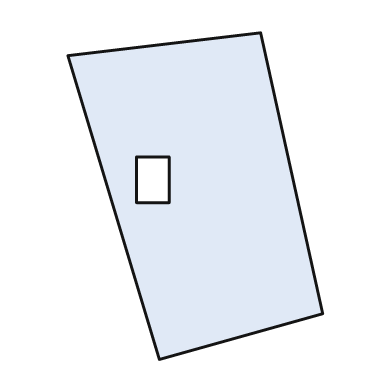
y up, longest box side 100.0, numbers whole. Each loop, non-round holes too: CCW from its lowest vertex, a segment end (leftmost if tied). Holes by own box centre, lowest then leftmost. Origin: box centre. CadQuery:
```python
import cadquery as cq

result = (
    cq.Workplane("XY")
    .moveTo(-11.0, -50.0)
    .lineTo(39.0, -36.0)
    .lineTo(20.0, 50.0)
    .lineTo(-39.0, 43.0)
    .close()
    .moveTo(-18.0, -2.0)
    .lineTo(-8.0, -2.0)
    .lineTo(-8.0, 12.0)
    .lineTo(-18.0, 12.0)
    .close()
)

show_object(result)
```